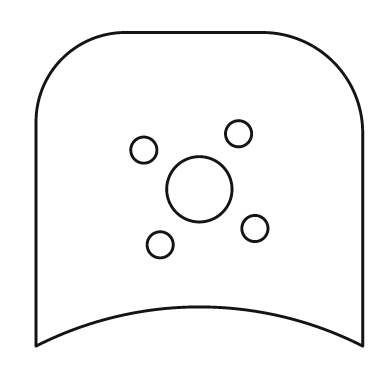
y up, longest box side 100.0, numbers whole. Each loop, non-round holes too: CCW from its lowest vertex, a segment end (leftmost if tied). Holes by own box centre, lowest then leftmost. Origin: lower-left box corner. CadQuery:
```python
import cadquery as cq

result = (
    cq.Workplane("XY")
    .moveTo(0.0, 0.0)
    .threePointArc((50.0, 12.0), (100.0, 0.0))
    .lineTo(100.0, 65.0)
    .threePointArc((91.0, 87.0), (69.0, 96.0))
    .lineTo(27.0, 96.0)
    .threePointArc((8.0, 88.0), (0.0, 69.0))
    .close()
    .moveTo(38.0, 31.0)
    .circle(4.0)
    .moveTo(67.0, 36.0)
    .circle(4.0)
    .moveTo(50.0, 48.0)
    .circle(10.0)
    .moveTo(33.0, 60.0)
    .circle(4.0)
    .moveTo(62.0, 65.0)
    .circle(4.0)
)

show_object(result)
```